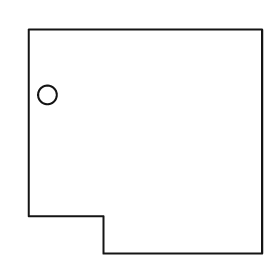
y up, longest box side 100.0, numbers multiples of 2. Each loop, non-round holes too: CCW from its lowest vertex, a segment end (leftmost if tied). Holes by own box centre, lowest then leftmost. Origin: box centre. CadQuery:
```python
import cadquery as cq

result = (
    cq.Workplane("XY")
    .moveTo(-18.0, -48.0)
    .lineTo(50.0, -48.0)
    .lineTo(50.0, 48.0)
    .lineTo(-50.0, 48.0)
    .lineTo(-50.0, -32.0)
    .lineTo(-18.0, -32.0)
    .close()
    .moveTo(-42.0, 20.0)
    .circle(4.0)
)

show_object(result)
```